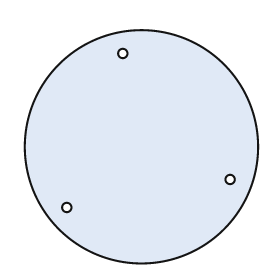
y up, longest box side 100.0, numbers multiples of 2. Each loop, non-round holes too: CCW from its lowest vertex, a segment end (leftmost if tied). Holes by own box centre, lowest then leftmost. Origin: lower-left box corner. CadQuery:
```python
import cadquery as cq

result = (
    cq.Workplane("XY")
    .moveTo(50.0, 50.0)
    .circle(50.0)
    .moveTo(18.0, 24.0)
    .circle(2.0)
    .moveTo(88.0, 36.0)
    .circle(2.0)
    .moveTo(42.0, 90.0)
    .circle(2.0)
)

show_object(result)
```